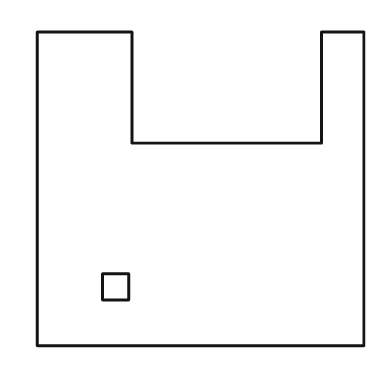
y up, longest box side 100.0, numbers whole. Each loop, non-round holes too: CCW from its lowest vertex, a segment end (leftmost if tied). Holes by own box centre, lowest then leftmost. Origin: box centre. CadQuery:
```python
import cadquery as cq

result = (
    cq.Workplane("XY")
    .moveTo(-50.0, -48.0)
    .lineTo(50.0, -48.0)
    .lineTo(50.0, 48.0)
    .lineTo(37.0, 48.0)
    .lineTo(37.0, 14.0)
    .lineTo(-21.0, 14.0)
    .lineTo(-21.0, 48.0)
    .lineTo(-50.0, 48.0)
    .close()
    .moveTo(-30.0, -34.0)
    .lineTo(-22.0, -34.0)
    .lineTo(-22.0, -26.0)
    .lineTo(-30.0, -26.0)
    .close()
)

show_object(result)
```